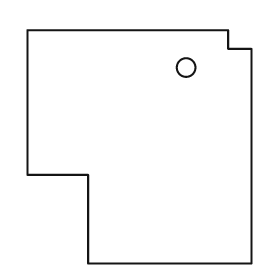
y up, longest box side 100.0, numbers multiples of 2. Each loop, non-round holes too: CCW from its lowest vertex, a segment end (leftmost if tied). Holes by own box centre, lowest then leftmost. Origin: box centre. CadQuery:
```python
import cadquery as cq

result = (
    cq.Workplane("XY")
    .moveTo(-22.0, -50.0)
    .lineTo(48.0, -50.0)
    .lineTo(48.0, 42.0)
    .lineTo(38.0, 42.0)
    .lineTo(38.0, 50.0)
    .lineTo(-48.0, 50.0)
    .lineTo(-48.0, -12.0)
    .lineTo(-22.0, -12.0)
    .close()
    .moveTo(20.0, 34.0)
    .circle(4.0)
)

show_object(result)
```